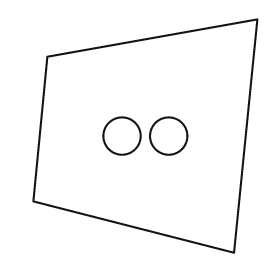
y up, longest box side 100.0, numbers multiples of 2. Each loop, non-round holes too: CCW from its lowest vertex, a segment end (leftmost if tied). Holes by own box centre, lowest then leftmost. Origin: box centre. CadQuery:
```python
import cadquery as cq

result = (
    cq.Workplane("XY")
    .moveTo(38.0, -50.0)
    .lineTo(48.0, 50.0)
    .lineTo(-42.0, 34.0)
    .lineTo(-48.0, -28.0)
    .close()
    .moveTo(-10.0, 0.0)
    .circle(8.0)
    .moveTo(10.0, 0.0)
    .circle(8.0)
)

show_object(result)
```